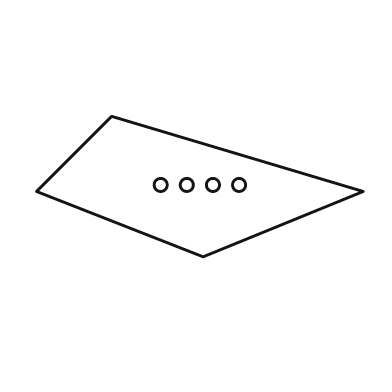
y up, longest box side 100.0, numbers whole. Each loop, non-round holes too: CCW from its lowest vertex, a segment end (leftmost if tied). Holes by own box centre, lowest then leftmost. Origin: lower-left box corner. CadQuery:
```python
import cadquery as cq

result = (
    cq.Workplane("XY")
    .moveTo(51.0, 0.0)
    .lineTo(100.0, 20.0)
    .lineTo(23.0, 43.0)
    .lineTo(0.0, 20.0)
    .close()
    .moveTo(38.0, 22.0)
    .circle(2.0)
    .moveTo(46.0, 22.0)
    .circle(2.0)
    .moveTo(54.0, 22.0)
    .circle(2.0)
    .moveTo(62.0, 22.0)
    .circle(2.0)
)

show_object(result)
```